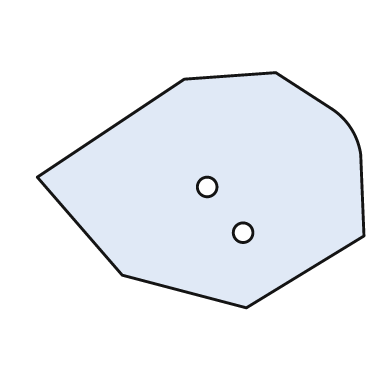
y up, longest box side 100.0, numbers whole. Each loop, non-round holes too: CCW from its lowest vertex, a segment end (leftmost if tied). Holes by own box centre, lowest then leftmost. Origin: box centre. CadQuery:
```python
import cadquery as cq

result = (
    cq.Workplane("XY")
    .moveTo(14.0, -36.0)
    .lineTo(50.0, -14.0)
    .lineTo(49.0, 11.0)
    .threePointArc((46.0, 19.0), (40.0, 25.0))
    .lineTo(23.0, 36.0)
    .lineTo(-5.0, 34.0)
    .lineTo(-50.0, 4.0)
    .lineTo(-24.0, -26.0)
    .close()
    .moveTo(13.0, -13.0)
    .circle(3.0)
    .moveTo(2.0, 1.0)
    .circle(3.0)
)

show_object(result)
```